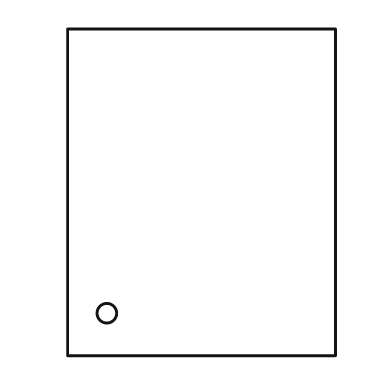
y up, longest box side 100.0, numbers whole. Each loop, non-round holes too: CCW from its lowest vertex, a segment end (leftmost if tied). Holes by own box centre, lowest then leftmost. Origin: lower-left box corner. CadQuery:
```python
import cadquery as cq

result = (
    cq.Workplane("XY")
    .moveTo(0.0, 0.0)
    .lineTo(82.0, 0.0)
    .lineTo(82.0, 100.0)
    .lineTo(0.0, 100.0)
    .close()
    .moveTo(12.0, 13.0)
    .circle(3.0)
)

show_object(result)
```